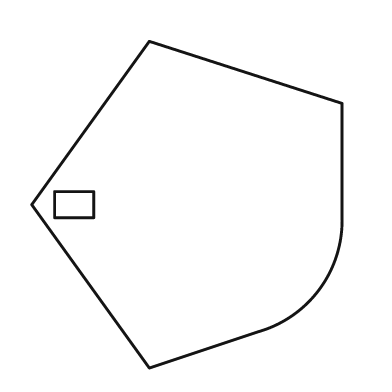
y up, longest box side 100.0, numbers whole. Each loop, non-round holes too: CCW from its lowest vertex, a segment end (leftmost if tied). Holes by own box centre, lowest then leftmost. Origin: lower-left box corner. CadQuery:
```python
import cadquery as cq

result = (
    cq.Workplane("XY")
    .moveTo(36.0, 0.0)
    .lineTo(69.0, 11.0)
    .threePointArc((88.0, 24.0), (95.0, 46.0))
    .lineTo(95.0, 81.0)
    .lineTo(36.0, 100.0)
    .lineTo(0.0, 50.0)
    .close()
    .moveTo(7.0, 46.0)
    .lineTo(19.0, 46.0)
    .lineTo(19.0, 54.0)
    .lineTo(7.0, 54.0)
    .close()
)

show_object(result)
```